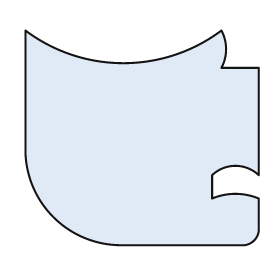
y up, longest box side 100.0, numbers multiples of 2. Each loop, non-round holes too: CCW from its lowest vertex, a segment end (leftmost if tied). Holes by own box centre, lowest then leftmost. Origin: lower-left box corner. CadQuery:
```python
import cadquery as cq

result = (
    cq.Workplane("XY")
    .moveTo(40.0, 0.0)
    .lineTo(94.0, 0.0)
    .threePointArc((98.0, 2.0), (100.0, 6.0))
    .lineTo(100.0, 20.0)
    .threePointArc((90.0, 22.0), (80.0, 20.0))
    .lineTo(80.0, 30.0)
    .threePointArc((90.0, 34.0), (100.0, 30.0))
    .lineTo(100.0, 76.0)
    .lineTo(84.0, 76.0)
    .threePointArc((86.0, 84.0), (84.0, 92.0))
    .threePointArc((42.0, 78.0), (0.0, 92.0))
    .lineTo(0.0, 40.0)
    .threePointArc((12.0, 12.0), (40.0, 0.0))
    .close()
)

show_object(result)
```